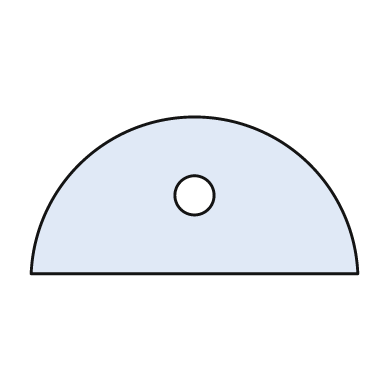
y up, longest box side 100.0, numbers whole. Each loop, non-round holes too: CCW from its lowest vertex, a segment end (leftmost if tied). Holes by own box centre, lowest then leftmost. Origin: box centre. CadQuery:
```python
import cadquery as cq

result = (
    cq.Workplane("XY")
    .moveTo(-50.0, -24.0)
    .lineTo(50.0, -24.0)
    .threePointArc((0.0, 24.0), (-50.0, -24.0))
    .close()
    .moveTo(0.0, 0.0)
    .circle(6.0)
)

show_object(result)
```